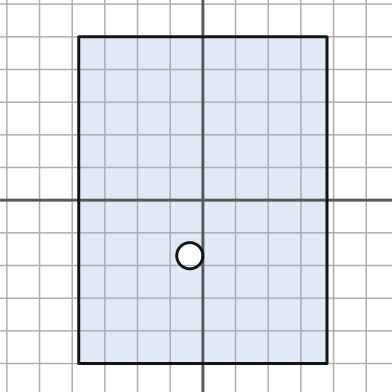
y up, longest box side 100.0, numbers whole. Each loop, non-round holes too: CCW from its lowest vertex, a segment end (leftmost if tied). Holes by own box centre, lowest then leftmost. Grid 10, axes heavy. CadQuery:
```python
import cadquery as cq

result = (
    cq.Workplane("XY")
    .moveTo(-38.0, -50.0)
    .lineTo(38.0, -50.0)
    .lineTo(38.0, 50.0)
    .lineTo(-38.0, 50.0)
    .close()
    .moveTo(-4.0, -17.0)
    .circle(4.0)
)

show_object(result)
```